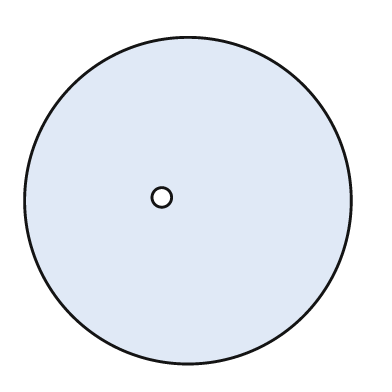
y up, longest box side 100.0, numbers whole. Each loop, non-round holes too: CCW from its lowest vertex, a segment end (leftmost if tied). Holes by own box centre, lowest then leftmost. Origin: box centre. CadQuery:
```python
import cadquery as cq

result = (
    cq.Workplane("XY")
    .moveTo(0.0, 0.0)
    .circle(50.0)
    .moveTo(-8.0, 1.0)
    .circle(3.0)
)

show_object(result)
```